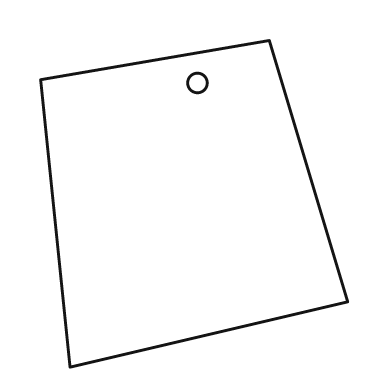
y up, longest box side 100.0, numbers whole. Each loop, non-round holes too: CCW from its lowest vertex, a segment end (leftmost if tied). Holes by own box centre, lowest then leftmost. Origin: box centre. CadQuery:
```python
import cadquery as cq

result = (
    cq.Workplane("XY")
    .moveTo(-38.0, -50.0)
    .lineTo(47.0, -30.0)
    .lineTo(23.0, 50.0)
    .lineTo(-47.0, 38.0)
    .close()
    .moveTo(1.0, 37.0)
    .circle(3.0)
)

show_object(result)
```